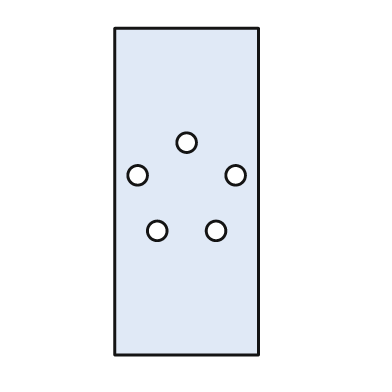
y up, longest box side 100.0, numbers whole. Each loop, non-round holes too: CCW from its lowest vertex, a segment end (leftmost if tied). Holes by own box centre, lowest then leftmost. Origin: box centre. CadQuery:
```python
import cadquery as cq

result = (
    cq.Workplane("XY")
    .moveTo(-22.0, -50.0)
    .lineTo(22.0, -50.0)
    .lineTo(22.0, 50.0)
    .lineTo(-22.0, 50.0)
    .close()
    .moveTo(-9.0, -12.0)
    .circle(3.0)
    .moveTo(9.0, -12.0)
    .circle(3.0)
    .moveTo(-15.0, 5.0)
    .circle(3.0)
    .moveTo(15.0, 5.0)
    .circle(3.0)
    .moveTo(0.0, 15.0)
    .circle(3.0)
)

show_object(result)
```